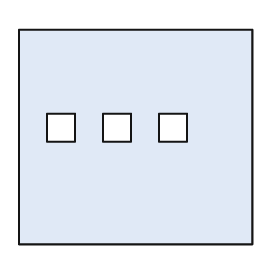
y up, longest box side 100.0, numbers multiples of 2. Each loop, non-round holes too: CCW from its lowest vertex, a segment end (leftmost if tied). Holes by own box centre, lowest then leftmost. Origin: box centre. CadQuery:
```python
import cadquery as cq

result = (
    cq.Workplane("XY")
    .moveTo(-50.0, -46.0)
    .lineTo(50.0, -46.0)
    .lineTo(50.0, 46.0)
    .lineTo(-50.0, 46.0)
    .close()
    .moveTo(-38.0, -2.0)
    .lineTo(-26.0, -2.0)
    .lineTo(-26.0, 10.0)
    .lineTo(-38.0, 10.0)
    .close()
    .moveTo(-14.0, -2.0)
    .lineTo(-2.0, -2.0)
    .lineTo(-2.0, 10.0)
    .lineTo(-14.0, 10.0)
    .close()
    .moveTo(10.0, -2.0)
    .lineTo(22.0, -2.0)
    .lineTo(22.0, 10.0)
    .lineTo(10.0, 10.0)
    .close()
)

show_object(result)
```